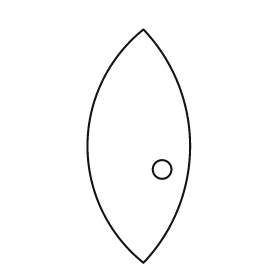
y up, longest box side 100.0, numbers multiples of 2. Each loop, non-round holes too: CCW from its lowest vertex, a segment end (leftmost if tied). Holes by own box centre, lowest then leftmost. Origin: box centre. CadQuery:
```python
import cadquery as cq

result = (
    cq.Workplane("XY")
    .moveTo(2.0, -50.0)
    .threePointArc((22.0, 0.0), (2.0, 50.0))
    .threePointArc((-22.0, 0.0), (2.0, -50.0))
    .close()
    .moveTo(10.0, -10.0)
    .circle(4.0)
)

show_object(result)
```